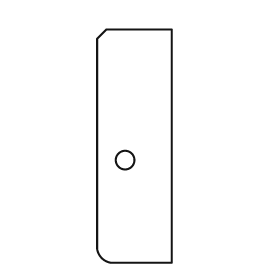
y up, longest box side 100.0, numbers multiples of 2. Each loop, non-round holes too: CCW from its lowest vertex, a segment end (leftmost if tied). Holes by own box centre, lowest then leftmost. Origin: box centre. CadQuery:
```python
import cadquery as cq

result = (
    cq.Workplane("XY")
    .moveTo(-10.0, -50.0)
    .lineTo(16.0, -50.0)
    .lineTo(16.0, 50.0)
    .lineTo(-12.0, 50.0)
    .lineTo(-16.0, 46.0)
    .lineTo(-16.0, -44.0)
    .threePointArc((-14.0, -48.0), (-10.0, -50.0))
    .close()
    .moveTo(-4.0, -6.0)
    .circle(4.0)
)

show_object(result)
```